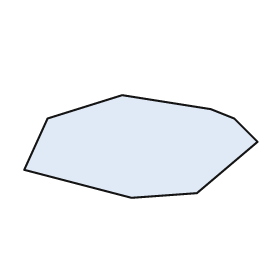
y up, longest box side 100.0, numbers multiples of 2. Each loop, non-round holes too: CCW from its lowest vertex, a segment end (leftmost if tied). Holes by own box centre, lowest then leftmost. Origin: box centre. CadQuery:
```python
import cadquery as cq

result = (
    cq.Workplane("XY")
    .moveTo(-4.0, -22.0)
    .lineTo(24.0, -20.0)
    .lineTo(50.0, 2.0)
    .lineTo(40.0, 12.0)
    .lineTo(30.0, 16.0)
    .lineTo(-8.0, 22.0)
    .lineTo(-40.0, 12.0)
    .lineTo(-50.0, -10.0)
    .close()
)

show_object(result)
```